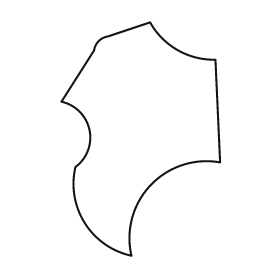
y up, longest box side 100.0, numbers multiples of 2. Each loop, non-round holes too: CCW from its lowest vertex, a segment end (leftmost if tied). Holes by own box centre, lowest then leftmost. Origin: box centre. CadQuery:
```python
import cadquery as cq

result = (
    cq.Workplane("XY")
    .moveTo(-4.0, -50.0)
    .threePointArc((4.0, -20.0), (34.0, -10.0))
    .lineTo(32.0, 34.0)
    .threePointArc((16.0, 38.0), (4.0, 50.0))
    .lineTo(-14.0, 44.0)
    .threePointArc((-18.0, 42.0), (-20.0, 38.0))
    .lineTo(-34.0, 16.0)
    .threePointArc((-22.0, 4.0), (-28.0, -12.0))
    .threePointArc((-24.0, -36.0), (-4.0, -50.0))
    .close()
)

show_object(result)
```